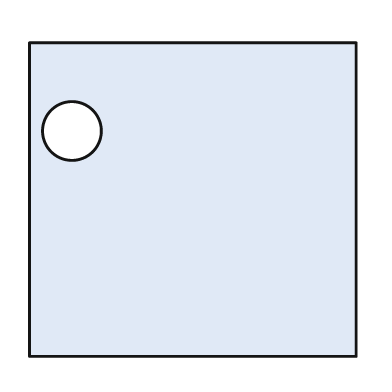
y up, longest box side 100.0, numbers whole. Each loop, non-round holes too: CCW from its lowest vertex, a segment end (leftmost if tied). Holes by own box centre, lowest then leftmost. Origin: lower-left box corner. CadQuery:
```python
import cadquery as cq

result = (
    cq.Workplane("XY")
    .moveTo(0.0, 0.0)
    .lineTo(100.0, 0.0)
    .lineTo(100.0, 96.0)
    .lineTo(0.0, 96.0)
    .close()
    .moveTo(13.0, 69.0)
    .circle(9.0)
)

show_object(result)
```